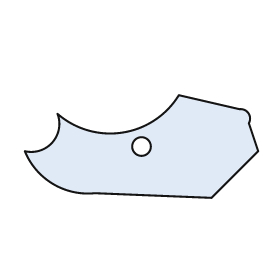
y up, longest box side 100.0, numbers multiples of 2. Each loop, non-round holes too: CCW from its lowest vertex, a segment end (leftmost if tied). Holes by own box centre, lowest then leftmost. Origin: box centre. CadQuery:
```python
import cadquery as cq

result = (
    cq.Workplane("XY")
    .moveTo(30.0, -22.0)
    .lineTo(50.0, -2.0)
    .lineTo(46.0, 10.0)
    .threePointArc((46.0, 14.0), (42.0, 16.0))
    .lineTo(16.0, 22.0)
    .threePointArc((-8.0, 6.0), (-36.0, 14.0))
    .threePointArc((-38.0, 2.0), (-50.0, -2.0))
    .threePointArc((-38.0, -16.0), (-20.0, -20.0))
    .close()
    .moveTo(0.0, 0.0)
    .circle(4.0)
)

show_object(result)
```